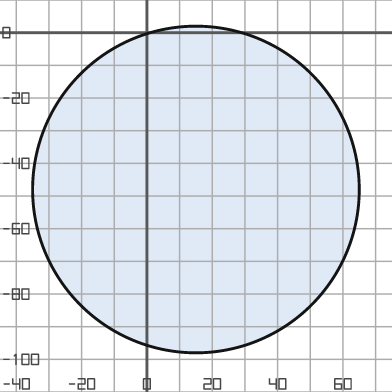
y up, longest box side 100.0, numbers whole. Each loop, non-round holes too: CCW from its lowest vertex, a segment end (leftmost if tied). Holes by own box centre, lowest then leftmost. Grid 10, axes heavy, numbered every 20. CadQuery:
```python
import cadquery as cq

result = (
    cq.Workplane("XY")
    .moveTo(15.0, -48.0)
    .circle(50.0)
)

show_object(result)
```